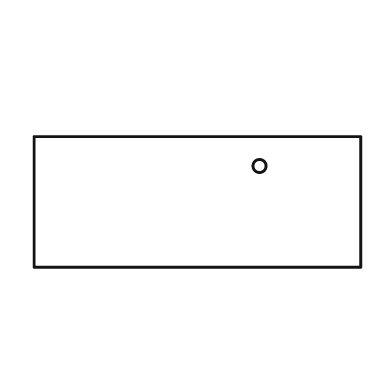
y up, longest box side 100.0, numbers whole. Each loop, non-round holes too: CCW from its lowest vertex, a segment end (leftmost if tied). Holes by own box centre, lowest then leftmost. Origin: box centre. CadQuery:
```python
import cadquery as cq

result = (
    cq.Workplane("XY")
    .moveTo(-50.0, -20.0)
    .lineTo(50.0, -20.0)
    .lineTo(50.0, 20.0)
    .lineTo(-50.0, 20.0)
    .close()
    .moveTo(19.0, 11.0)
    .circle(2.0)
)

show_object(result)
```